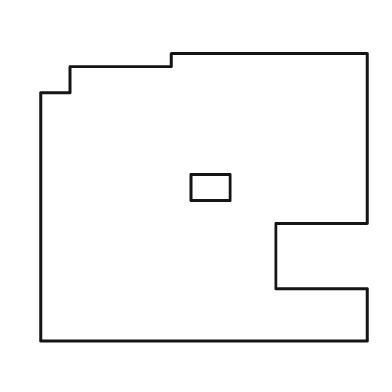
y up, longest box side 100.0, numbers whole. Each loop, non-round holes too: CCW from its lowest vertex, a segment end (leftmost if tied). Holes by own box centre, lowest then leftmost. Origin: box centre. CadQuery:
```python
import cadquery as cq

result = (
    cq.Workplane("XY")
    .moveTo(-50.0, -44.0)
    .lineTo(50.0, -44.0)
    .lineTo(50.0, -28.0)
    .lineTo(22.0, -28.0)
    .lineTo(22.0, -8.0)
    .lineTo(50.0, -8.0)
    .lineTo(50.0, 44.0)
    .lineTo(-10.0, 44.0)
    .lineTo(-10.0, 40.0)
    .lineTo(-41.0, 40.0)
    .lineTo(-41.0, 32.0)
    .lineTo(-50.0, 32.0)
    .close()
    .moveTo(-4.0, -1.0)
    .lineTo(8.0, -1.0)
    .lineTo(8.0, 7.0)
    .lineTo(-4.0, 7.0)
    .close()
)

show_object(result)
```